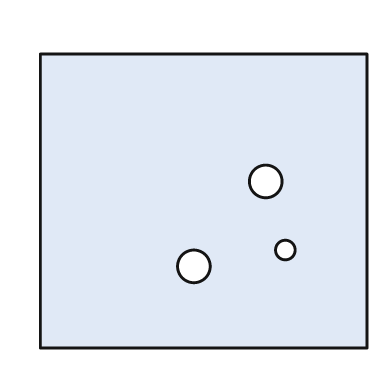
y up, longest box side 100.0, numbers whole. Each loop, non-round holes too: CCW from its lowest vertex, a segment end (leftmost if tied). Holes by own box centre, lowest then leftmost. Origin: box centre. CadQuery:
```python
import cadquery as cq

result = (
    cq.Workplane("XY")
    .moveTo(-50.0, -45.0)
    .lineTo(50.0, -45.0)
    .lineTo(50.0, 45.0)
    .lineTo(-50.0, 45.0)
    .close()
    .moveTo(-3.0, -20.0)
    .circle(5.0)
    .moveTo(25.0, -15.0)
    .circle(3.0)
    .moveTo(19.0, 6.0)
    .circle(5.0)
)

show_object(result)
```